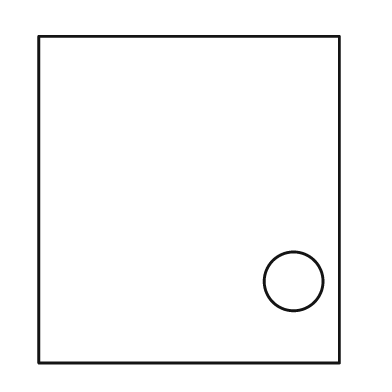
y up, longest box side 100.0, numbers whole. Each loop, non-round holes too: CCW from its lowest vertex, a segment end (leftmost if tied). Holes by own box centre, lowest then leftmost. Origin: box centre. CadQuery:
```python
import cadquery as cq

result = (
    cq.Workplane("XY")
    .moveTo(-46.0, -50.0)
    .lineTo(46.0, -50.0)
    .lineTo(46.0, 50.0)
    .lineTo(-46.0, 50.0)
    .close()
    .moveTo(32.0, -25.0)
    .circle(9.0)
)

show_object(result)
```